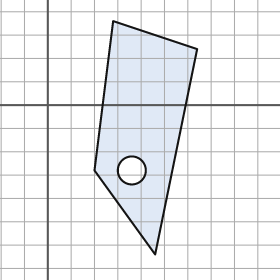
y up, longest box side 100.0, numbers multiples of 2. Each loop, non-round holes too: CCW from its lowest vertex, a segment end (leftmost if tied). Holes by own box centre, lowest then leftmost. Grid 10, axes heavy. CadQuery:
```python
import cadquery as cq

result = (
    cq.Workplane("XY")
    .moveTo(46.0, -64.0)
    .lineTo(64.0, 24.0)
    .lineTo(28.0, 36.0)
    .lineTo(20.0, -28.0)
    .close()
    .moveTo(36.0, -28.0)
    .circle(6.0)
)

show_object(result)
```